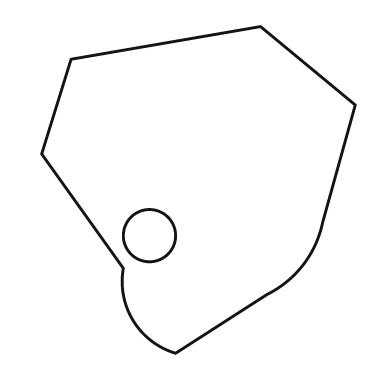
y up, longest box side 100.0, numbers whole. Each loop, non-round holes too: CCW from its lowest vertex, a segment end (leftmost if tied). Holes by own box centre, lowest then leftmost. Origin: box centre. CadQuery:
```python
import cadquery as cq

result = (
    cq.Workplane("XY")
    .moveTo(-7.0, -50.0)
    .lineTo(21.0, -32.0)
    .threePointArc((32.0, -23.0), (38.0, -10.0))
    .lineTo(48.0, 26.0)
    .lineTo(19.0, 50.0)
    .lineTo(-39.0, 40.0)
    .lineTo(-48.0, 11.0)
    .lineTo(-23.0, -24.0)
    .threePointArc((-20.0, -40.0), (-7.0, -50.0))
    .close()
    .moveTo(-15.0, -14.0)
    .circle(8.0)
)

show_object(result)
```